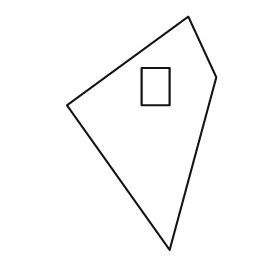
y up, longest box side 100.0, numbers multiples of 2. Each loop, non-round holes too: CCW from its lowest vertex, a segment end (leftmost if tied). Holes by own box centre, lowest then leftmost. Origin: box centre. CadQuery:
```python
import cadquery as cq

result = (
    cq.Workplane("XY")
    .moveTo(12.0, -50.0)
    .lineTo(32.0, 24.0)
    .lineTo(20.0, 50.0)
    .lineTo(-32.0, 12.0)
    .close()
    .moveTo(0.0, 12.0)
    .lineTo(12.0, 12.0)
    .lineTo(12.0, 28.0)
    .lineTo(0.0, 28.0)
    .close()
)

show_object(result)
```